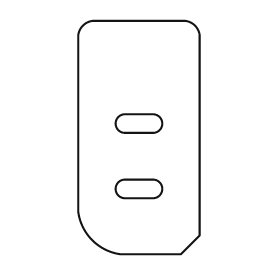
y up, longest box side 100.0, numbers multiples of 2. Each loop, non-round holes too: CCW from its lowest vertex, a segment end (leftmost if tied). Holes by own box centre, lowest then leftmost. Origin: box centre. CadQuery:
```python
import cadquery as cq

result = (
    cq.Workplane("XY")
    .moveTo(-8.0, -50.0)
    .lineTo(18.0, -50.0)
    .lineTo(26.0, -42.0)
    .lineTo(26.0, 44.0)
    .threePointArc((24.0, 48.0), (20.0, 50.0))
    .lineTo(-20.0, 50.0)
    .threePointArc((-24.0, 48.0), (-26.0, 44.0))
    .lineTo(-26.0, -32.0)
    .threePointArc((-20.0, -44.0), (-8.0, -50.0))
    .close()
    .moveTo(-6.0, -26.0)
    .lineTo(6.0, -26.0)
    .threePointArc((10.0, -22.0), (6.0, -18.0))
    .lineTo(-6.0, -18.0)
    .threePointArc((-10.0, -22.0), (-6.0, -26.0))
    .close()
    .moveTo(-6.0, 2.0)
    .lineTo(6.0, 2.0)
    .threePointArc((10.0, 6.0), (6.0, 10.0))
    .lineTo(-6.0, 10.0)
    .threePointArc((-10.0, 6.0), (-6.0, 2.0))
    .close()
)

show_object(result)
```